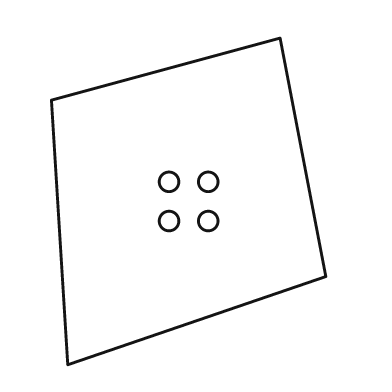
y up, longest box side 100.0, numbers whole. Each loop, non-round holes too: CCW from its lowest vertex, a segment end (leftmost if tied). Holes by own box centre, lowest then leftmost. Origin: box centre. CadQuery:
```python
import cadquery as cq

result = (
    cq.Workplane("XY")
    .moveTo(-37.0, -50.0)
    .lineTo(42.0, -23.0)
    .lineTo(28.0, 50.0)
    .lineTo(-42.0, 31.0)
    .close()
    .moveTo(-6.0, -6.0)
    .circle(3.0)
    .moveTo(6.0, -6.0)
    .circle(3.0)
    .moveTo(-6.0, 6.0)
    .circle(3.0)
    .moveTo(6.0, 6.0)
    .circle(3.0)
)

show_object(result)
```